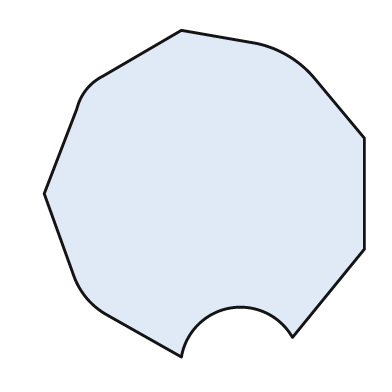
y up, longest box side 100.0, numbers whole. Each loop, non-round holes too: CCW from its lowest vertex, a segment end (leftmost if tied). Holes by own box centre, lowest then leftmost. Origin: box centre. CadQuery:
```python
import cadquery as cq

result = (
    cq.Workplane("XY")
    .moveTo(-7.0, -50.0)
    .threePointArc((8.0, -35.0), (27.0, -44.0))
    .lineTo(49.0, -17.0)
    .lineTo(49.0, 17.0)
    .lineTo(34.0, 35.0)
    .threePointArc((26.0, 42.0), (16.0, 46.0))
    .lineTo(-7.0, 50.0)
    .lineTo(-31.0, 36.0)
    .threePointArc((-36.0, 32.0), (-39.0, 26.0))
    .lineTo(-49.0, 0.0)
    .lineTo(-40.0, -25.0)
    .threePointArc((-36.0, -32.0), (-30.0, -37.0))
    .close()
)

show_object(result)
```